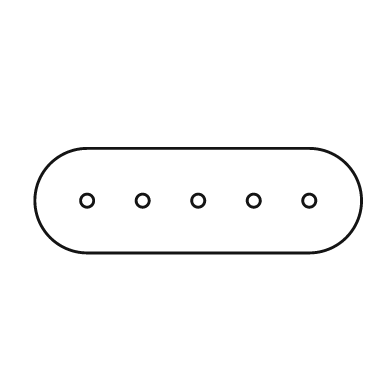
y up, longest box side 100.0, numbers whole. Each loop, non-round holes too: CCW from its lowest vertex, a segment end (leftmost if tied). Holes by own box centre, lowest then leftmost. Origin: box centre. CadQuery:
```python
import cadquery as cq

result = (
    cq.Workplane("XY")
    .moveTo(-34.0, -16.0)
    .lineTo(34.0, -16.0)
    .threePointArc((50.0, 0.0), (34.0, 16.0))
    .lineTo(-34.0, 16.0)
    .threePointArc((-50.0, 0.0), (-34.0, -16.0))
    .close()
    .moveTo(-34.0, 0.0)
    .circle(2.0)
    .moveTo(-17.0, 0.0)
    .circle(2.0)
    .moveTo(0.0, 0.0)
    .circle(2.0)
    .moveTo(17.0, 0.0)
    .circle(2.0)
    .moveTo(34.0, 0.0)
    .circle(2.0)
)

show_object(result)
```